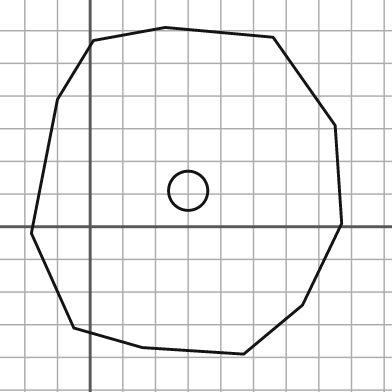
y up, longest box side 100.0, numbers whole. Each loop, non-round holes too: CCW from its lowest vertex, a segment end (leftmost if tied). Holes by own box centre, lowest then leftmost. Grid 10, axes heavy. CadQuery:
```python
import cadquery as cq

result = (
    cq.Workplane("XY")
    .moveTo(47.0, -39.0)
    .lineTo(65.0, -24.0)
    .lineTo(77.0, 1.0)
    .lineTo(75.0, 31.0)
    .lineTo(56.0, 58.0)
    .lineTo(23.0, 61.0)
    .lineTo(1.0, 57.0)
    .lineTo(-10.0, 39.0)
    .lineTo(-18.0, -2.0)
    .lineTo(-5.0, -31.0)
    .lineTo(16.0, -37.0)
    .close()
    .moveTo(30.0, 11.0)
    .circle(6.0)
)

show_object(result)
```